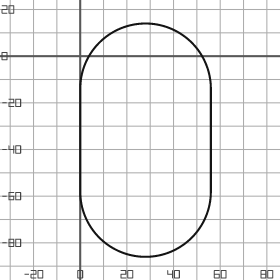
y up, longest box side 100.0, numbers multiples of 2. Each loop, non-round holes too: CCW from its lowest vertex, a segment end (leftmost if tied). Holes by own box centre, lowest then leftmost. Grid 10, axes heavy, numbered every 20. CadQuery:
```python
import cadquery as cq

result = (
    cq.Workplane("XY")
    .moveTo(0.0, -58.0)
    .threePointArc((28.0, -86.0), (56.0, -58.0))
    .lineTo(56.0, -14.0)
    .threePointArc((28.0, 14.0), (0.0, -14.0))
    .close()
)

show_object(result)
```